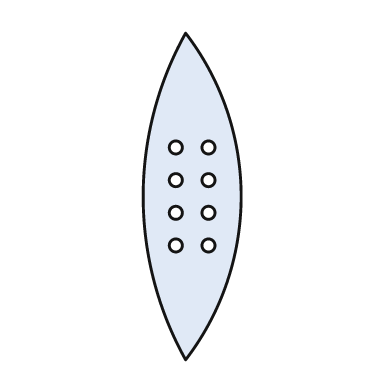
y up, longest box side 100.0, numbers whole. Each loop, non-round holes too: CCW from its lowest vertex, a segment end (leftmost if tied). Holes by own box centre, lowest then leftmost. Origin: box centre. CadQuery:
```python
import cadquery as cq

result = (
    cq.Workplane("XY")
    .moveTo(-2.0, -50.0)
    .threePointArc((15.0, 0.0), (-2.0, 50.0))
    .threePointArc((-15.0, 0.0), (-2.0, -50.0))
    .close()
    .moveTo(-5.0, -15.0)
    .circle(2.0)
    .moveTo(5.0, -15.0)
    .circle(2.0)
    .moveTo(-5.0, -5.0)
    .circle(2.0)
    .moveTo(5.0, -5.0)
    .circle(2.0)
    .moveTo(-5.0, 5.0)
    .circle(2.0)
    .moveTo(5.0, 5.0)
    .circle(2.0)
    .moveTo(-5.0, 15.0)
    .circle(2.0)
    .moveTo(5.0, 15.0)
    .circle(2.0)
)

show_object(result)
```